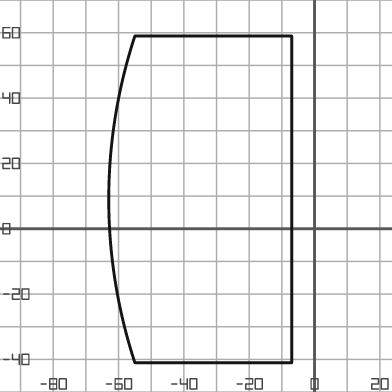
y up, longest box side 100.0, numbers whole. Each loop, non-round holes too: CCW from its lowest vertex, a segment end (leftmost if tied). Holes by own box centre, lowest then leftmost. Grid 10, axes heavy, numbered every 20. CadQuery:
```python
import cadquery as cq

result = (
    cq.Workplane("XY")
    .moveTo(-55.0, -41.0)
    .lineTo(-7.0, -41.0)
    .lineTo(-7.0, 59.0)
    .lineTo(-55.0, 59.0)
    .threePointArc((-63.0, 9.0), (-55.0, -41.0))
    .close()
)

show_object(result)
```